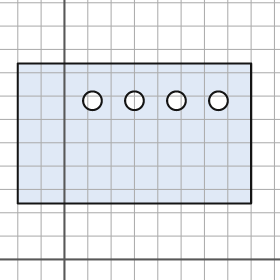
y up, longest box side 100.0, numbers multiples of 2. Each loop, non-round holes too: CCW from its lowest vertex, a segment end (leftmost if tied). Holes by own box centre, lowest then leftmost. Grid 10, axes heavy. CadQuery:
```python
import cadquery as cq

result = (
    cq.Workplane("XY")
    .moveTo(-20.0, 24.0)
    .lineTo(80.0, 24.0)
    .lineTo(80.0, 84.0)
    .lineTo(-20.0, 84.0)
    .close()
    .moveTo(12.0, 68.0)
    .circle(4.0)
    .moveTo(30.0, 68.0)
    .circle(4.0)
    .moveTo(48.0, 68.0)
    .circle(4.0)
    .moveTo(66.0, 68.0)
    .circle(4.0)
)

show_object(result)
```